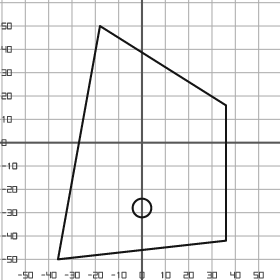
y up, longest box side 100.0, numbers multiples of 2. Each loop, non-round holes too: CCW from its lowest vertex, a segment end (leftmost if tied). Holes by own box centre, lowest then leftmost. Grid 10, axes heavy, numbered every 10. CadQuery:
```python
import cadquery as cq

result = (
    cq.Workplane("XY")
    .moveTo(-36.0, -50.0)
    .lineTo(36.0, -42.0)
    .lineTo(36.0, 16.0)
    .lineTo(-18.0, 50.0)
    .close()
    .moveTo(0.0, -28.0)
    .circle(4.0)
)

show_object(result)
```